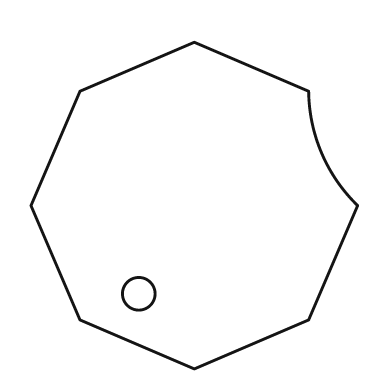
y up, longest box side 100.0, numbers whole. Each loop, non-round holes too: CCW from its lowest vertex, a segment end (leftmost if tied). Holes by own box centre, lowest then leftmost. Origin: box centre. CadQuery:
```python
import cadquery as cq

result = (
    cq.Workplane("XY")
    .moveTo(0.0, -50.0)
    .lineTo(35.0, -35.0)
    .lineTo(50.0, 0.0)
    .threePointArc((39.0, 16.0), (35.0, 35.0))
    .lineTo(0.0, 50.0)
    .lineTo(-35.0, 35.0)
    .lineTo(-50.0, 0.0)
    .lineTo(-35.0, -35.0)
    .close()
    .moveTo(-17.0, -27.0)
    .circle(5.0)
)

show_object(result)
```